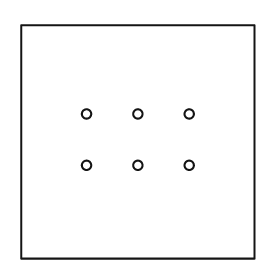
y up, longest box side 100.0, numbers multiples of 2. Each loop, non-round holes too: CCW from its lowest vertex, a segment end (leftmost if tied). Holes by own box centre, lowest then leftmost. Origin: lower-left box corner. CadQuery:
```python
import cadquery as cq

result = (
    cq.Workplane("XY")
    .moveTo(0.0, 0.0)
    .lineTo(100.0, 0.0)
    .lineTo(100.0, 100.0)
    .lineTo(0.0, 100.0)
    .close()
    .moveTo(28.0, 40.0)
    .circle(2.0)
    .moveTo(50.0, 40.0)
    .circle(2.0)
    .moveTo(72.0, 40.0)
    .circle(2.0)
    .moveTo(28.0, 62.0)
    .circle(2.0)
    .moveTo(50.0, 62.0)
    .circle(2.0)
    .moveTo(72.0, 62.0)
    .circle(2.0)
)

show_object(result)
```